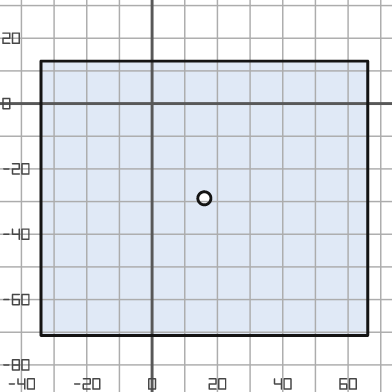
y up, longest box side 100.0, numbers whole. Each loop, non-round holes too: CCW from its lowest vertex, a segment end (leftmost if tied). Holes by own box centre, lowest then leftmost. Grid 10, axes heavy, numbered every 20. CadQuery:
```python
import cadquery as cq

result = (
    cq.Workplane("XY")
    .moveTo(-34.0, -71.0)
    .lineTo(66.0, -71.0)
    .lineTo(66.0, 13.0)
    .lineTo(-34.0, 13.0)
    .close()
    .moveTo(16.0, -29.0)
    .circle(2.0)
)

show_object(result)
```